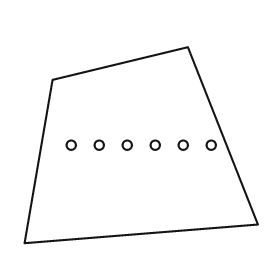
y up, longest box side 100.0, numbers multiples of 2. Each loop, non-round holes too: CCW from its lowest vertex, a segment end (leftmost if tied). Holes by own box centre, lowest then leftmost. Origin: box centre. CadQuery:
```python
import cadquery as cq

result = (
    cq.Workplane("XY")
    .moveTo(-50.0, -42.0)
    .lineTo(50.0, -34.0)
    .lineTo(20.0, 42.0)
    .lineTo(-38.0, 28.0)
    .close()
    .moveTo(-30.0, 0.0)
    .circle(2.0)
    .moveTo(-18.0, 0.0)
    .circle(2.0)
    .moveTo(-6.0, 0.0)
    .circle(2.0)
    .moveTo(6.0, 0.0)
    .circle(2.0)
    .moveTo(18.0, 0.0)
    .circle(2.0)
    .moveTo(30.0, 0.0)
    .circle(2.0)
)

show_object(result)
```